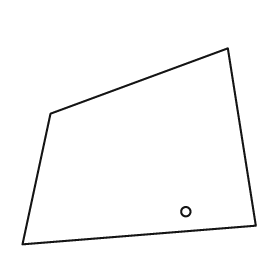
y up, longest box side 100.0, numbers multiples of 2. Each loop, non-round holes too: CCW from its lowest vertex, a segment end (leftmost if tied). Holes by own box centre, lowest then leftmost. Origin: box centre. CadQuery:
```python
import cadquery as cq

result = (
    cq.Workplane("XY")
    .moveTo(-50.0, -42.0)
    .lineTo(50.0, -34.0)
    .lineTo(38.0, 42.0)
    .lineTo(-38.0, 14.0)
    .close()
    .moveTo(20.0, -28.0)
    .circle(2.0)
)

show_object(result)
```